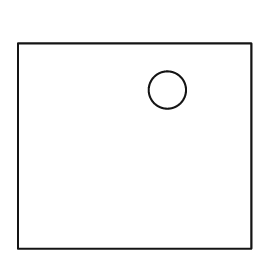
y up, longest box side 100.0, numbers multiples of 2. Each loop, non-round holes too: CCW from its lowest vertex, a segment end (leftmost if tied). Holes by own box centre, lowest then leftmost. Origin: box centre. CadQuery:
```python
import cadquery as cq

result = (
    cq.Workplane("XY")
    .moveTo(-50.0, -44.0)
    .lineTo(50.0, -44.0)
    .lineTo(50.0, 44.0)
    .lineTo(-50.0, 44.0)
    .close()
    .moveTo(14.0, 24.0)
    .circle(8.0)
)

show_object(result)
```